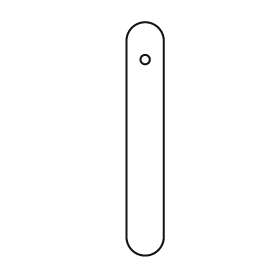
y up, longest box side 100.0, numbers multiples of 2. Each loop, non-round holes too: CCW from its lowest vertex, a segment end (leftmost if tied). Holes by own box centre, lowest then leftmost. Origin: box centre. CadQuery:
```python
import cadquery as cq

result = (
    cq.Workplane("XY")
    .moveTo(-8.0, -42.0)
    .threePointArc((0.0, -50.0), (8.0, -42.0))
    .lineTo(8.0, 42.0)
    .threePointArc((0.0, 50.0), (-8.0, 42.0))
    .close()
    .moveTo(0.0, 34.0)
    .circle(2.0)
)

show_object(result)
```